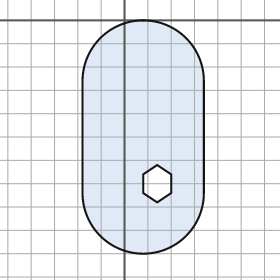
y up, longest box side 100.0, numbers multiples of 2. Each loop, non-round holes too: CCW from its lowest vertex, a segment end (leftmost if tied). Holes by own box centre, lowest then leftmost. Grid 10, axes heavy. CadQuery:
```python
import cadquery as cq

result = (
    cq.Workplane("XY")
    .moveTo(-18.0, -74.0)
    .threePointArc((8.0, -100.0), (34.0, -74.0))
    .lineTo(34.0, -26.0)
    .threePointArc((8.0, 0.0), (-18.0, -26.0))
    .close()
    .moveTo(14.0, -78.0)
    .lineTo(20.0, -74.0)
    .lineTo(20.0, -66.0)
    .lineTo(14.0, -62.0)
    .lineTo(8.0, -66.0)
    .lineTo(8.0, -74.0)
    .close()
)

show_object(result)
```